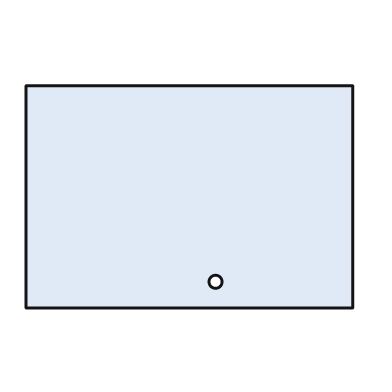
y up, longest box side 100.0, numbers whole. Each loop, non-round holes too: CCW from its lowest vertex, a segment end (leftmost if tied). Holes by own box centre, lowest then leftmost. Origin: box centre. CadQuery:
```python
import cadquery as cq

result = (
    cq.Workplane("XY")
    .moveTo(-50.0, -34.0)
    .lineTo(50.0, -34.0)
    .lineTo(50.0, 34.0)
    .lineTo(-50.0, 34.0)
    .close()
    .moveTo(8.0, -26.0)
    .circle(2.0)
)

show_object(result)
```